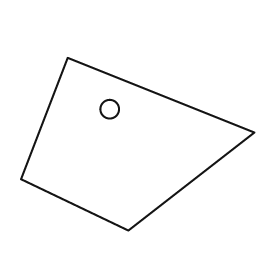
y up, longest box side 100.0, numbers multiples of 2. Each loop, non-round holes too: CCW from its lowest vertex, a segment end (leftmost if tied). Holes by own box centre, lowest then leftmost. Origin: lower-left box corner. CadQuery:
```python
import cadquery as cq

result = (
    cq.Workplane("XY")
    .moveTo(46.0, 0.0)
    .lineTo(100.0, 42.0)
    .lineTo(20.0, 74.0)
    .lineTo(0.0, 22.0)
    .close()
    .moveTo(38.0, 52.0)
    .circle(4.0)
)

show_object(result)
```